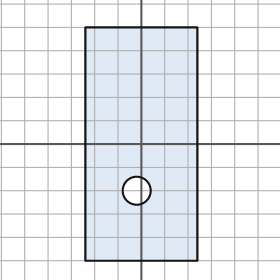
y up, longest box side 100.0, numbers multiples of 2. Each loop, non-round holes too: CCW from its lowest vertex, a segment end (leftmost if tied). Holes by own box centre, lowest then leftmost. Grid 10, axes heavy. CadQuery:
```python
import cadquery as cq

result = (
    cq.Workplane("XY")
    .moveTo(-24.0, -50.0)
    .lineTo(24.0, -50.0)
    .lineTo(24.0, 50.0)
    .lineTo(-24.0, 50.0)
    .close()
    .moveTo(-2.0, -20.0)
    .circle(6.0)
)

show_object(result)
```